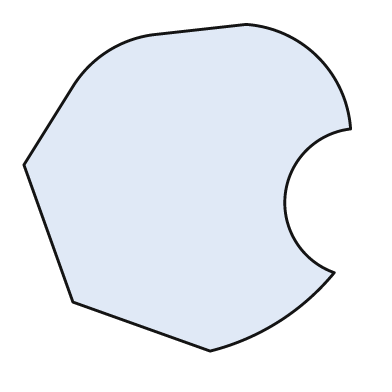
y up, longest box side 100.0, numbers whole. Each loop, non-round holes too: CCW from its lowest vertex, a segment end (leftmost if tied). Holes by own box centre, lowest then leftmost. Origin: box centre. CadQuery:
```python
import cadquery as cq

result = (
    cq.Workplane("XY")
    .moveTo(7.0, -50.0)
    .threePointArc((28.0, -41.0), (45.0, -26.0))
    .threePointArc((30.0, -2.0), (50.0, 18.0))
    .threePointArc((40.0, 40.0), (18.0, 50.0))
    .lineTo(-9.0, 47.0)
    .threePointArc((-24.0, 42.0), (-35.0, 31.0))
    .lineTo(-50.0, 7.0)
    .lineTo(-35.0, -35.0)
    .close()
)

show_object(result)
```